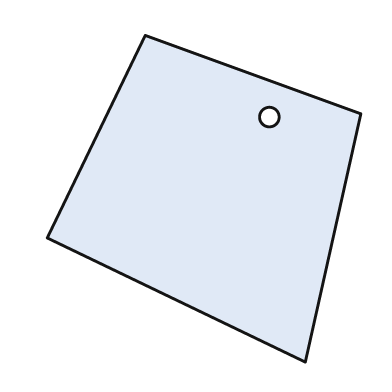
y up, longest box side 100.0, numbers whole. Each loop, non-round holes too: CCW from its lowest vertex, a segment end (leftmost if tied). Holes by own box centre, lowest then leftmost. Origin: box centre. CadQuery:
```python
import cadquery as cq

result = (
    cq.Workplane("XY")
    .moveTo(31.0, -50.0)
    .lineTo(48.0, 26.0)
    .lineTo(-18.0, 50.0)
    .lineTo(-48.0, -12.0)
    .close()
    .moveTo(20.0, 25.0)
    .circle(3.0)
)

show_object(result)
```